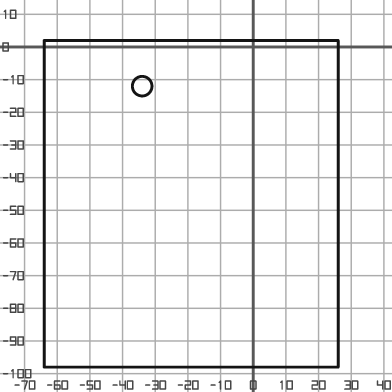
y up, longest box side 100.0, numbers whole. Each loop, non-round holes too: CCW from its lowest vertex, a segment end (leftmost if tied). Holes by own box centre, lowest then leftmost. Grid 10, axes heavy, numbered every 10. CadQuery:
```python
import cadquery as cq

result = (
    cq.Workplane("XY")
    .moveTo(-64.0, -98.0)
    .lineTo(26.0, -98.0)
    .lineTo(26.0, 2.0)
    .lineTo(-64.0, 2.0)
    .close()
    .moveTo(-34.0, -12.0)
    .circle(3.0)
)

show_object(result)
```